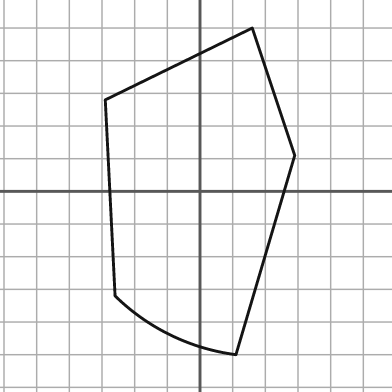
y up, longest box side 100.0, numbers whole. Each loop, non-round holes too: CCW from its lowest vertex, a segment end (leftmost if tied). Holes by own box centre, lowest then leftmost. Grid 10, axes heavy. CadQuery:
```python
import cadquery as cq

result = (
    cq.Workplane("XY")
    .moveTo(11.0, -50.0)
    .lineTo(29.0, 11.0)
    .lineTo(16.0, 50.0)
    .lineTo(-29.0, 28.0)
    .lineTo(-26.0, -32.0)
    .threePointArc((-9.0, -44.0), (11.0, -50.0))
    .close()
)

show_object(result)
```